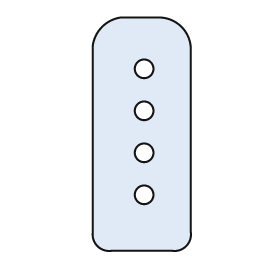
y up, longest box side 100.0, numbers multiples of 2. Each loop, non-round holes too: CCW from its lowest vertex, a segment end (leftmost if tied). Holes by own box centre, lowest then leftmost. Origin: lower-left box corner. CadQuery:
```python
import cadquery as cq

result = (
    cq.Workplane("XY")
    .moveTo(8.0, 0.0)
    .lineTo(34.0, 0.0)
    .threePointArc((40.0, 2.0), (42.0, 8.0))
    .lineTo(42.0, 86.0)
    .threePointArc((38.0, 96.0), (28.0, 100.0))
    .lineTo(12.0, 100.0)
    .threePointArc((4.0, 96.0), (0.0, 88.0))
    .lineTo(0.0, 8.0)
    .threePointArc((2.0, 2.0), (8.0, 0.0))
    .close()
    .moveTo(22.0, 24.0)
    .circle(4.0)
    .moveTo(22.0, 42.0)
    .circle(4.0)
    .moveTo(22.0, 60.0)
    .circle(4.0)
    .moveTo(22.0, 78.0)
    .circle(4.0)
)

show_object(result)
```